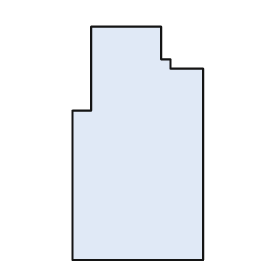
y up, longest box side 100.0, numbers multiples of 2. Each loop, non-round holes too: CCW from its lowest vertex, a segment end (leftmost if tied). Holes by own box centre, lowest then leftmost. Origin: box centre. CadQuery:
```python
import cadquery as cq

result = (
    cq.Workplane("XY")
    .moveTo(-28.0, -50.0)
    .lineTo(28.0, -50.0)
    .lineTo(28.0, 32.0)
    .lineTo(14.0, 32.0)
    .lineTo(14.0, 36.0)
    .lineTo(10.0, 36.0)
    .lineTo(10.0, 50.0)
    .lineTo(-20.0, 50.0)
    .lineTo(-20.0, 14.0)
    .lineTo(-28.0, 14.0)
    .close()
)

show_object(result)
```